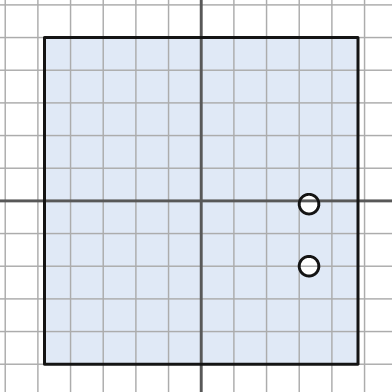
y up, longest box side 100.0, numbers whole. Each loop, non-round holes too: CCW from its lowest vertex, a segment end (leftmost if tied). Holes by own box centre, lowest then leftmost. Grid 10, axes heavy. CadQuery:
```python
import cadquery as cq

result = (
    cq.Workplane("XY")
    .moveTo(-48.0, -50.0)
    .lineTo(48.0, -50.0)
    .lineTo(48.0, 50.0)
    .lineTo(-48.0, 50.0)
    .close()
    .moveTo(33.0, -20.0)
    .circle(3.0)
    .moveTo(33.0, -1.0)
    .circle(3.0)
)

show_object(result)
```